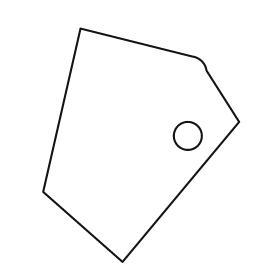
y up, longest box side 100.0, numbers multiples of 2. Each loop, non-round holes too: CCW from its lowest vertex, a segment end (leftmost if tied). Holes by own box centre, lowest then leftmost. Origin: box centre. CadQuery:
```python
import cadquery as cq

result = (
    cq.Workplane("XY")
    .moveTo(-8.0, -50.0)
    .lineTo(42.0, 10.0)
    .lineTo(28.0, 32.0)
    .threePointArc((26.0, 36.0), (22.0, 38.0))
    .lineTo(-26.0, 50.0)
    .lineTo(-42.0, -20.0)
    .close()
    .moveTo(20.0, 4.0)
    .circle(6.0)
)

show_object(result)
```